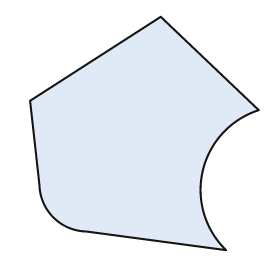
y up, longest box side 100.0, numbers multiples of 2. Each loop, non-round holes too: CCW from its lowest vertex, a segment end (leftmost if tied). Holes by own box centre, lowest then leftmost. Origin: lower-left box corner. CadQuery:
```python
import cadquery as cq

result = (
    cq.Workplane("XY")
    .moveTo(84.0, 0.0)
    .threePointArc((74.0, 34.0), (98.0, 60.0))
    .lineTo(56.0, 100.0)
    .lineTo(0.0, 64.0)
    .lineTo(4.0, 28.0)
    .threePointArc((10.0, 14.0), (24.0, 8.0))
    .close()
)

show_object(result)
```